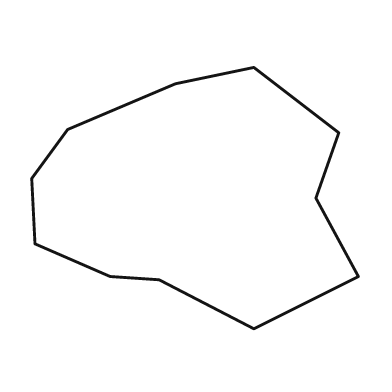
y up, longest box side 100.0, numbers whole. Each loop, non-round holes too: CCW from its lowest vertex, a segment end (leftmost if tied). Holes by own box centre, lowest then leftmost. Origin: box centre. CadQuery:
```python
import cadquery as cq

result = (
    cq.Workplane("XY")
    .moveTo(18.0, -40.0)
    .lineTo(50.0, -24.0)
    .lineTo(37.0, 0.0)
    .lineTo(44.0, 20.0)
    .lineTo(18.0, 40.0)
    .lineTo(-6.0, 35.0)
    .lineTo(-39.0, 21.0)
    .lineTo(-50.0, 6.0)
    .lineTo(-49.0, -14.0)
    .lineTo(-26.0, -24.0)
    .lineTo(-11.0, -25.0)
    .close()
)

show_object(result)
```